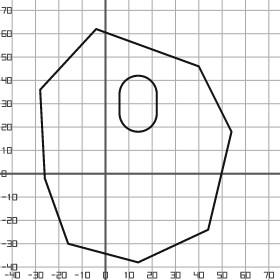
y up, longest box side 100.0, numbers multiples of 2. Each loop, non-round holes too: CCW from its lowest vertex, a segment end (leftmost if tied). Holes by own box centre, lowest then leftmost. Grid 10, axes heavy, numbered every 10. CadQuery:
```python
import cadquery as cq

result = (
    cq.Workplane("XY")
    .moveTo(14.0, -38.0)
    .lineTo(44.0, -24.0)
    .lineTo(54.0, 18.0)
    .lineTo(40.0, 46.0)
    .lineTo(-4.0, 62.0)
    .lineTo(-28.0, 36.0)
    .lineTo(-26.0, -2.0)
    .lineTo(-16.0, -30.0)
    .close()
    .moveTo(6.0, 26.0)
    .threePointArc((14.0, 18.0), (22.0, 26.0))
    .lineTo(22.0, 34.0)
    .threePointArc((14.0, 42.0), (6.0, 34.0))
    .close()
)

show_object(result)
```